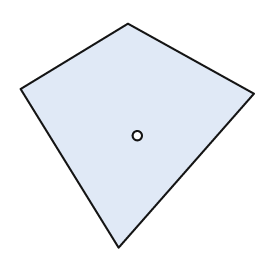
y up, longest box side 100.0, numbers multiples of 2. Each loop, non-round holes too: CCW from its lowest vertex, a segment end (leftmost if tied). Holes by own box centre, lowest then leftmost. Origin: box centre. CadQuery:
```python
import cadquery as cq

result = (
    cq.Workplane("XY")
    .moveTo(-8.0, -48.0)
    .lineTo(50.0, 18.0)
    .lineTo(-4.0, 48.0)
    .lineTo(-50.0, 20.0)
    .close()
    .moveTo(0.0, 0.0)
    .circle(2.0)
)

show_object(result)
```